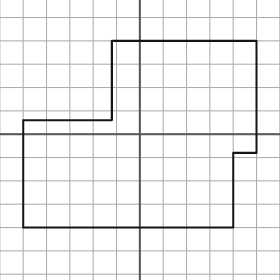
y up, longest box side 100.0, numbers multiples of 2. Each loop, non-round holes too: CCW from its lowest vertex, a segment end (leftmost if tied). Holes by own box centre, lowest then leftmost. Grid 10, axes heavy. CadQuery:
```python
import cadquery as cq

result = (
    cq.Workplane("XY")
    .moveTo(-50.0, -40.0)
    .lineTo(40.0, -40.0)
    .lineTo(40.0, -8.0)
    .lineTo(50.0, -8.0)
    .lineTo(50.0, 40.0)
    .lineTo(-12.0, 40.0)
    .lineTo(-12.0, 6.0)
    .lineTo(-50.0, 6.0)
    .close()
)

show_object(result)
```